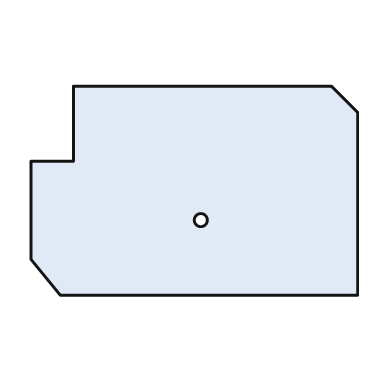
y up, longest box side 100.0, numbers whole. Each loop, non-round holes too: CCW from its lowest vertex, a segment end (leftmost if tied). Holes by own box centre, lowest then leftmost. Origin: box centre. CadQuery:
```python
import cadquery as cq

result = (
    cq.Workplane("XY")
    .moveTo(-41.0, -32.0)
    .lineTo(50.0, -32.0)
    .lineTo(50.0, 24.0)
    .lineTo(42.0, 32.0)
    .lineTo(-37.0, 32.0)
    .lineTo(-37.0, 9.0)
    .lineTo(-50.0, 9.0)
    .lineTo(-50.0, -21.0)
    .close()
    .moveTo(2.0, -9.0)
    .circle(2.0)
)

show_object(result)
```